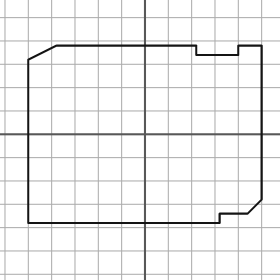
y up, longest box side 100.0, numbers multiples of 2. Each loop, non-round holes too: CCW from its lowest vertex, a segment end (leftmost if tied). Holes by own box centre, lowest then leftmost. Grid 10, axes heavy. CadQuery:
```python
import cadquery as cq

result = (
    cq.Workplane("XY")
    .moveTo(-50.0, -38.0)
    .lineTo(32.0, -38.0)
    .lineTo(32.0, -34.0)
    .lineTo(44.0, -34.0)
    .lineTo(50.0, -28.0)
    .lineTo(50.0, 38.0)
    .lineTo(40.0, 38.0)
    .lineTo(40.0, 34.0)
    .lineTo(22.0, 34.0)
    .lineTo(22.0, 38.0)
    .lineTo(-38.0, 38.0)
    .lineTo(-50.0, 32.0)
    .close()
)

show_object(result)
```